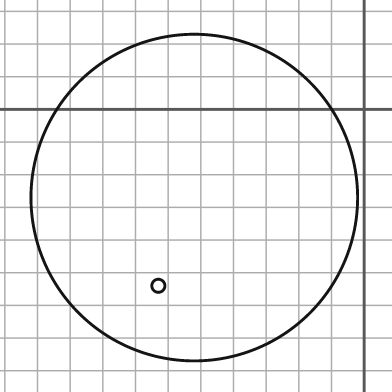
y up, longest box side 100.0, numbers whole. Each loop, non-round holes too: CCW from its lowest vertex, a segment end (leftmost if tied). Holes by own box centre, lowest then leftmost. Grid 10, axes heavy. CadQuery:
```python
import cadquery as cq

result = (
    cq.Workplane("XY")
    .moveTo(-52.0, -27.0)
    .circle(50.0)
    .moveTo(-63.0, -54.0)
    .circle(2.0)
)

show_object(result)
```